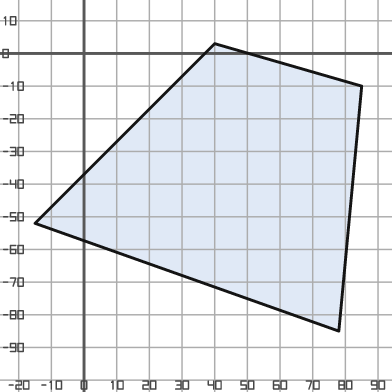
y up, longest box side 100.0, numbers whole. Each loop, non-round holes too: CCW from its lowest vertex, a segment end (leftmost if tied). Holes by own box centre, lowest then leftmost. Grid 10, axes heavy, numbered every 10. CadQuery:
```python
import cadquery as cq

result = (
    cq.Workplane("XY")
    .moveTo(78.0, -85.0)
    .lineTo(85.0, -10.0)
    .lineTo(40.0, 3.0)
    .lineTo(-15.0, -52.0)
    .close()
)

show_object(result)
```